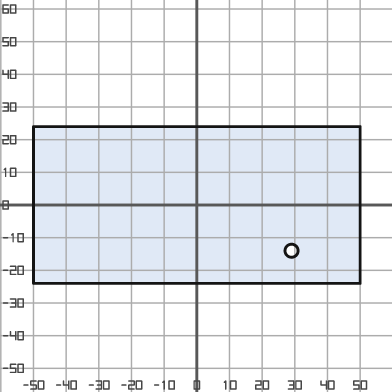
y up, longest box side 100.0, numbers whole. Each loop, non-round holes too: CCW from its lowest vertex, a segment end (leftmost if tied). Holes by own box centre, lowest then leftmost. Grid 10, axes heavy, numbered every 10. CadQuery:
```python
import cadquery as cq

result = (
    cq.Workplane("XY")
    .moveTo(-50.0, -24.0)
    .lineTo(50.0, -24.0)
    .lineTo(50.0, 24.0)
    .lineTo(-50.0, 24.0)
    .close()
    .moveTo(29.0, -14.0)
    .circle(2.0)
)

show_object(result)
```